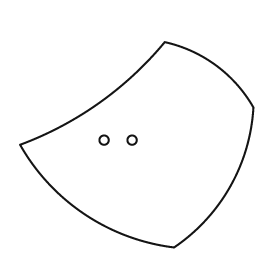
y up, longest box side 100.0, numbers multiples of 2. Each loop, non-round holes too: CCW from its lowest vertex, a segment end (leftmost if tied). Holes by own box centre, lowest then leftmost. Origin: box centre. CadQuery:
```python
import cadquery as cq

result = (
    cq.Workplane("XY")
    .moveTo(16.0, -44.0)
    .threePointArc((40.0, -18.0), (50.0, 16.0))
    .threePointArc((34.0, 34.0), (12.0, 44.0))
    .threePointArc((-16.0, 18.0), (-50.0, 0.0))
    .threePointArc((-22.0, -30.0), (16.0, -44.0))
    .close()
    .moveTo(-14.0, 2.0)
    .circle(2.0)
    .moveTo(-2.0, 2.0)
    .circle(2.0)
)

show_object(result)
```